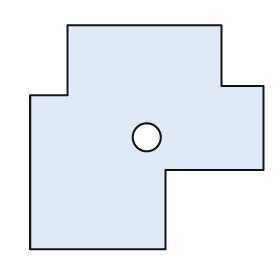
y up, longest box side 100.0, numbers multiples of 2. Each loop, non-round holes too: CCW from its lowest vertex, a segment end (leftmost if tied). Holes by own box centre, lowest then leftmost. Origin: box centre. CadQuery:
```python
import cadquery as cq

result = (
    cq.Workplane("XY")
    .moveTo(-50.0, -48.0)
    .lineTo(8.0, -48.0)
    .lineTo(8.0, -14.0)
    .lineTo(50.0, -14.0)
    .lineTo(50.0, 22.0)
    .lineTo(32.0, 22.0)
    .lineTo(32.0, 48.0)
    .lineTo(-34.0, 48.0)
    .lineTo(-34.0, 18.0)
    .lineTo(-50.0, 18.0)
    .close()
    .moveTo(0.0, 0.0)
    .circle(6.0)
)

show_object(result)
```